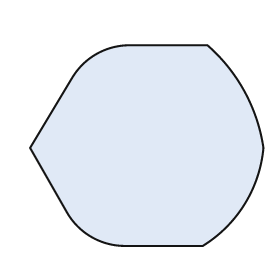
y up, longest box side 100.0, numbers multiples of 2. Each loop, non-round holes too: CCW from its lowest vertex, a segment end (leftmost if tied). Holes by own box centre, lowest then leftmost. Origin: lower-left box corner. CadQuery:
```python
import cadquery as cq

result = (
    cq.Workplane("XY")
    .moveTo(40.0, 0.0)
    .lineTo(74.0, 0.0)
    .threePointArc((92.0, 18.0), (100.0, 42.0))
    .threePointArc((92.0, 66.0), (76.0, 86.0))
    .lineTo(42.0, 86.0)
    .threePointArc((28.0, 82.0), (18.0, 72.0))
    .lineTo(0.0, 42.0)
    .lineTo(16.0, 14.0)
    .threePointArc((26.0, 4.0), (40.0, 0.0))
    .close()
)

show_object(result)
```